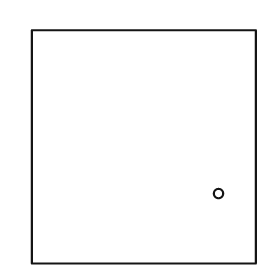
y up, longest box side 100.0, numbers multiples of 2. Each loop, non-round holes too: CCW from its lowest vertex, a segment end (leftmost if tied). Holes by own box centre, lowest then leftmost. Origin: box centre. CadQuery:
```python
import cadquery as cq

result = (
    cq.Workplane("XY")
    .moveTo(-48.0, -50.0)
    .lineTo(48.0, -50.0)
    .lineTo(48.0, 50.0)
    .lineTo(-48.0, 50.0)
    .close()
    .moveTo(32.0, -20.0)
    .circle(2.0)
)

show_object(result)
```